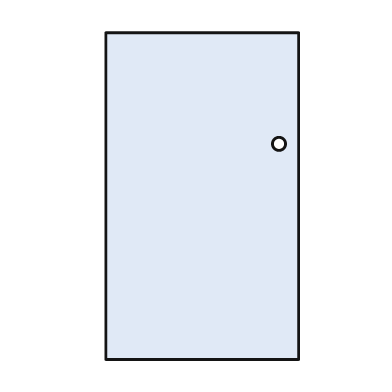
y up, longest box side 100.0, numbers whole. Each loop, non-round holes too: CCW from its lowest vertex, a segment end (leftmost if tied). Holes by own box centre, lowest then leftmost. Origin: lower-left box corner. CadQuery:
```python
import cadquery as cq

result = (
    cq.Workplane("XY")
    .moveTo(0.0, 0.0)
    .lineTo(59.0, 0.0)
    .lineTo(59.0, 100.0)
    .lineTo(0.0, 100.0)
    .close()
    .moveTo(53.0, 66.0)
    .circle(2.0)
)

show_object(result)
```